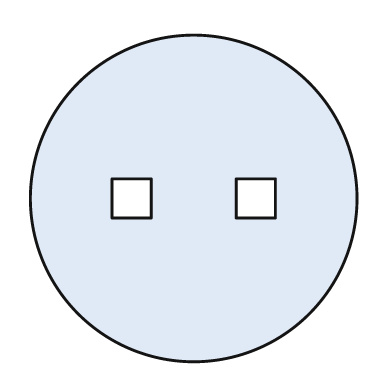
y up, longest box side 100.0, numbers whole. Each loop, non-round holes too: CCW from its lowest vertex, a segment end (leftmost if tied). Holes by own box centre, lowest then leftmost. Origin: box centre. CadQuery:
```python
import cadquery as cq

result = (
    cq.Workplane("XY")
    .moveTo(0.0, 0.0)
    .circle(50.0)
    .moveTo(-25.0, -6.0)
    .lineTo(-13.0, -6.0)
    .lineTo(-13.0, 6.0)
    .lineTo(-25.0, 6.0)
    .close()
    .moveTo(13.0, -6.0)
    .lineTo(25.0, -6.0)
    .lineTo(25.0, 6.0)
    .lineTo(13.0, 6.0)
    .close()
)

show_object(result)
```